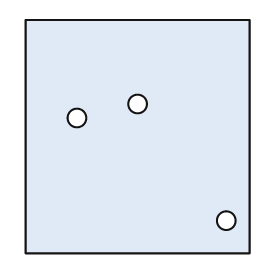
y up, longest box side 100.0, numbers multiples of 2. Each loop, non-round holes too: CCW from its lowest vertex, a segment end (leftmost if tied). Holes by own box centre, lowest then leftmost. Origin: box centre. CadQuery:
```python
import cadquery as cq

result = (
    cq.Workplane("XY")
    .moveTo(-48.0, -50.0)
    .lineTo(48.0, -50.0)
    .lineTo(48.0, 50.0)
    .lineTo(-48.0, 50.0)
    .close()
    .moveTo(38.0, -36.0)
    .circle(4.0)
    .moveTo(-26.0, 8.0)
    .circle(4.0)
    .moveTo(0.0, 14.0)
    .circle(4.0)
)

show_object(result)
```